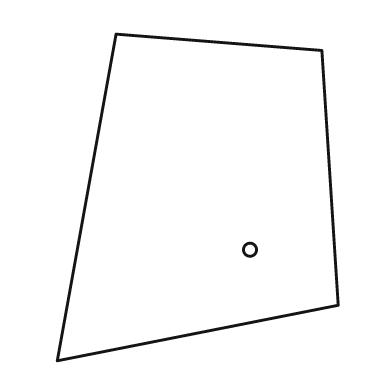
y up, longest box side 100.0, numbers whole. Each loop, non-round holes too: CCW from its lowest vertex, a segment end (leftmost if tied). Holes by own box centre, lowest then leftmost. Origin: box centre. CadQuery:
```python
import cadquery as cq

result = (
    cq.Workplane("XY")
    .moveTo(-43.0, -50.0)
    .lineTo(43.0, -33.0)
    .lineTo(38.0, 45.0)
    .lineTo(-25.0, 50.0)
    .close()
    .moveTo(16.0, -16.0)
    .circle(2.0)
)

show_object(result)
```